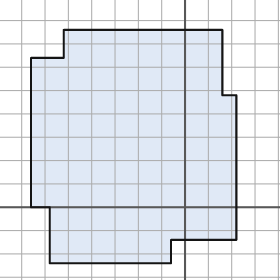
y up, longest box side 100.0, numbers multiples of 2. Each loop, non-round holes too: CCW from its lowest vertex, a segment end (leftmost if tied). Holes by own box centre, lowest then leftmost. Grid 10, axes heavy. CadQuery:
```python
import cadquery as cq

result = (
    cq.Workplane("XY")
    .moveTo(-58.0, -24.0)
    .lineTo(-6.0, -24.0)
    .lineTo(-6.0, -14.0)
    .lineTo(22.0, -14.0)
    .lineTo(22.0, 48.0)
    .lineTo(16.0, 48.0)
    .lineTo(16.0, 76.0)
    .lineTo(-52.0, 76.0)
    .lineTo(-52.0, 64.0)
    .lineTo(-66.0, 64.0)
    .lineTo(-66.0, 0.0)
    .lineTo(-58.0, 0.0)
    .close()
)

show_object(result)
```